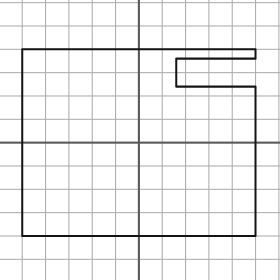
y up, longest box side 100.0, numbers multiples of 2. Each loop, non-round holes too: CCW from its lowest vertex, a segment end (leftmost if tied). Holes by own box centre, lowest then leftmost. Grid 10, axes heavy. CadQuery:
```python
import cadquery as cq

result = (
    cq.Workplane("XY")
    .moveTo(-50.0, -40.0)
    .lineTo(50.0, -40.0)
    .lineTo(50.0, 24.0)
    .lineTo(16.0, 24.0)
    .lineTo(16.0, 36.0)
    .lineTo(50.0, 36.0)
    .lineTo(50.0, 40.0)
    .lineTo(-50.0, 40.0)
    .close()
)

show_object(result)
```